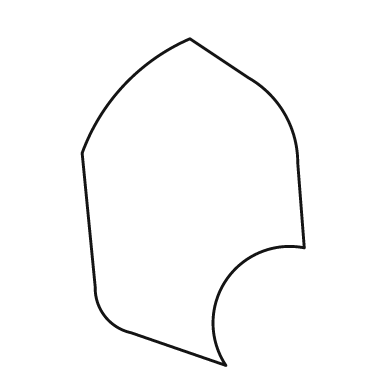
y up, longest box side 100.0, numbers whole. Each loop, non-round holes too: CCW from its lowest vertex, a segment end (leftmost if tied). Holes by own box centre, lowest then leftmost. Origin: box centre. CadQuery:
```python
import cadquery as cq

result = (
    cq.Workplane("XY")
    .moveTo(10.0, -50.0)
    .threePointArc((10.0, -24.0), (34.0, -14.0))
    .lineTo(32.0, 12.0)
    .threePointArc((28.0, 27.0), (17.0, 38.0))
    .lineTo(-1.0, 50.0)
    .threePointArc((-21.0, 36.0), (-34.0, 15.0))
    .lineTo(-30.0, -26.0)
    .threePointArc((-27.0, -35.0), (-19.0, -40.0))
    .close()
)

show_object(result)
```